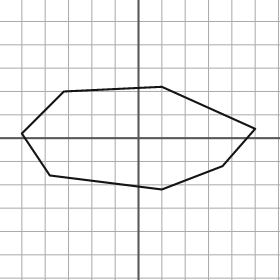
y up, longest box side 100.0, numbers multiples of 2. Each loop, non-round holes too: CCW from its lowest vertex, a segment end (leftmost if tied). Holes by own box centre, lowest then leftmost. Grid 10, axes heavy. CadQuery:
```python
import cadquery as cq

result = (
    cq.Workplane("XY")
    .moveTo(10.0, -22.0)
    .lineTo(36.0, -12.0)
    .lineTo(50.0, 4.0)
    .lineTo(10.0, 22.0)
    .lineTo(-32.0, 20.0)
    .lineTo(-50.0, 2.0)
    .lineTo(-38.0, -16.0)
    .close()
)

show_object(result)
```